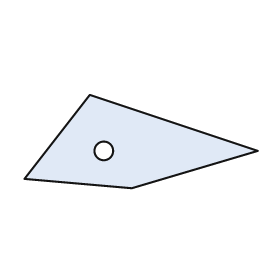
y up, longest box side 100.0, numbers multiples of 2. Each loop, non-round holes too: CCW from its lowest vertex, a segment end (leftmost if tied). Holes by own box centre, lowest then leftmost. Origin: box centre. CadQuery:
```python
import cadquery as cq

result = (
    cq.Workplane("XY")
    .moveTo(-4.0, -20.0)
    .lineTo(50.0, -4.0)
    .lineTo(-22.0, 20.0)
    .lineTo(-50.0, -16.0)
    .close()
    .moveTo(-16.0, -4.0)
    .circle(4.0)
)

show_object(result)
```